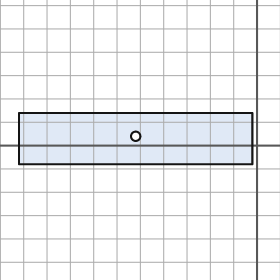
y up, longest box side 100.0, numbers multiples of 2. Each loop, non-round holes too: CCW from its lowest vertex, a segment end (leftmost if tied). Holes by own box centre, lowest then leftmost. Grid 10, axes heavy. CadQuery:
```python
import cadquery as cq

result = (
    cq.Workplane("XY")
    .moveTo(-102.0, -8.0)
    .lineTo(-2.0, -8.0)
    .lineTo(-2.0, 14.0)
    .lineTo(-102.0, 14.0)
    .close()
    .moveTo(-52.0, 4.0)
    .circle(2.0)
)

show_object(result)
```